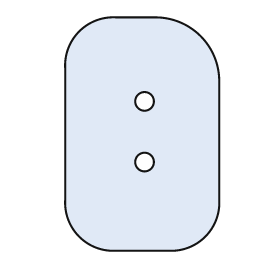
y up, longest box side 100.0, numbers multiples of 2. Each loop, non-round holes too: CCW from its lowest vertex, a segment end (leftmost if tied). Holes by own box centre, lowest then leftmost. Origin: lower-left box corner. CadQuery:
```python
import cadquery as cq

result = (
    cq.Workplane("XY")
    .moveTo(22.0, 0.0)
    .lineTo(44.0, 0.0)
    .threePointArc((60.0, 6.0), (66.0, 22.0))
    .lineTo(66.0, 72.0)
    .threePointArc((58.0, 92.0), (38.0, 100.0))
    .lineTo(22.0, 100.0)
    .threePointArc((6.0, 94.0), (0.0, 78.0))
    .lineTo(0.0, 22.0)
    .threePointArc((6.0, 6.0), (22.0, 0.0))
    .close()
    .moveTo(34.0, 38.0)
    .circle(4.0)
    .moveTo(34.0, 64.0)
    .circle(4.0)
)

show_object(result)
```